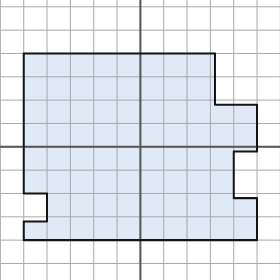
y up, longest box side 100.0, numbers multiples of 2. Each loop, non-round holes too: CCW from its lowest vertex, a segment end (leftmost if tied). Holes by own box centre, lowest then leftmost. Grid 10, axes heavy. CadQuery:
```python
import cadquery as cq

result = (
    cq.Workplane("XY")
    .moveTo(-50.0, -40.0)
    .lineTo(50.0, -40.0)
    .lineTo(50.0, -22.0)
    .lineTo(40.0, -22.0)
    .lineTo(40.0, -2.0)
    .lineTo(50.0, -2.0)
    .lineTo(50.0, 18.0)
    .lineTo(32.0, 18.0)
    .lineTo(32.0, 40.0)
    .lineTo(-50.0, 40.0)
    .lineTo(-50.0, -20.0)
    .lineTo(-40.0, -20.0)
    .lineTo(-40.0, -32.0)
    .lineTo(-50.0, -32.0)
    .close()
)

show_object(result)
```